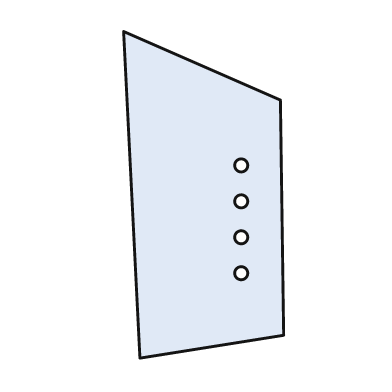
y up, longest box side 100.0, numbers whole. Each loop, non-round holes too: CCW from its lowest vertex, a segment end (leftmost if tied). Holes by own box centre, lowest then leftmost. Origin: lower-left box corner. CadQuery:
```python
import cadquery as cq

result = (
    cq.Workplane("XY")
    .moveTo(5.0, 0.0)
    .lineTo(49.0, 7.0)
    .lineTo(48.0, 79.0)
    .lineTo(0.0, 100.0)
    .close()
    .moveTo(36.0, 26.0)
    .circle(2.0)
    .moveTo(36.0, 37.0)
    .circle(2.0)
    .moveTo(36.0, 48.0)
    .circle(2.0)
    .moveTo(36.0, 59.0)
    .circle(2.0)
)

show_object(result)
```